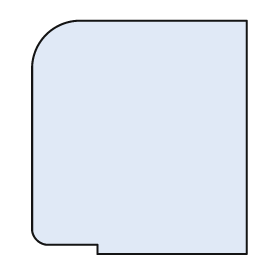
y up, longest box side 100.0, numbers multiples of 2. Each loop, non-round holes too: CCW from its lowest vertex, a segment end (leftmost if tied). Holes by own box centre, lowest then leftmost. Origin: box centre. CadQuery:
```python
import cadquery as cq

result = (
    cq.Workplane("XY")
    .moveTo(-18.0, -50.0)
    .lineTo(46.0, -50.0)
    .lineTo(46.0, 50.0)
    .lineTo(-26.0, 50.0)
    .threePointArc((-40.0, 44.0), (-46.0, 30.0))
    .lineTo(-46.0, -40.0)
    .threePointArc((-44.0, -44.0), (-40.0, -46.0))
    .lineTo(-18.0, -46.0)
    .close()
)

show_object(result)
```